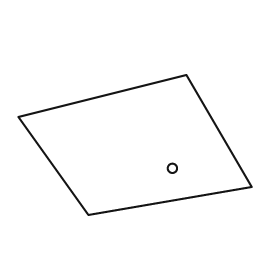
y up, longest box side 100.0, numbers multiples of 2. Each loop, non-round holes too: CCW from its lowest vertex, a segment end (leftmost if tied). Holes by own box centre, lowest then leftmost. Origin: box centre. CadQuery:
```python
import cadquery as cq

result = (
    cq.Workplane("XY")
    .moveTo(-20.0, -30.0)
    .lineTo(50.0, -18.0)
    .lineTo(22.0, 30.0)
    .lineTo(-50.0, 12.0)
    .close()
    .moveTo(16.0, -10.0)
    .circle(2.0)
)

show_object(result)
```